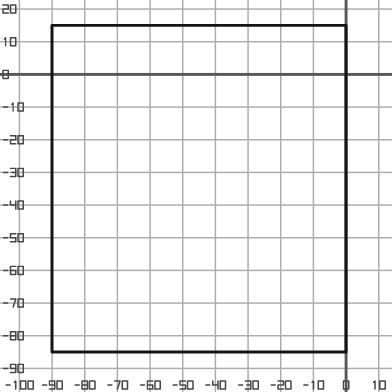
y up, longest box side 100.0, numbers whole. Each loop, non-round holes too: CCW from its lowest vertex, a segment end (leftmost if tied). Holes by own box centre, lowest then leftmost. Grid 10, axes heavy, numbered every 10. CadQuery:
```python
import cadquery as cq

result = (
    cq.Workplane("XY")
    .moveTo(-90.0, -85.0)
    .lineTo(0.0, -85.0)
    .lineTo(0.0, 15.0)
    .lineTo(-90.0, 15.0)
    .close()
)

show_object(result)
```